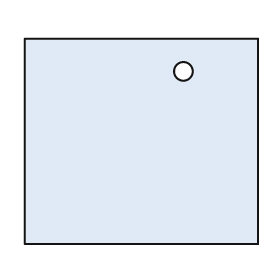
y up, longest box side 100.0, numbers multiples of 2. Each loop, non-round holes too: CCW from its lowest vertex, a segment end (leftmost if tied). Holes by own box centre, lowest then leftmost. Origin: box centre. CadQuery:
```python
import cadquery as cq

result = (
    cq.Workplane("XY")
    .moveTo(-50.0, -44.0)
    .lineTo(50.0, -44.0)
    .lineTo(50.0, 44.0)
    .lineTo(-50.0, 44.0)
    .close()
    .moveTo(18.0, 30.0)
    .circle(4.0)
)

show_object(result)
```